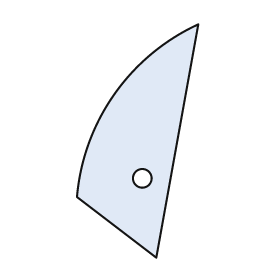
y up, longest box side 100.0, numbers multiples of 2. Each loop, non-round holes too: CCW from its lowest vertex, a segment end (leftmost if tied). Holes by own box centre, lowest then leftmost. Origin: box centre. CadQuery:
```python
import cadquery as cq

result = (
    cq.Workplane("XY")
    .moveTo(8.0, -50.0)
    .lineTo(26.0, 50.0)
    .threePointArc((-10.0, 20.0), (-26.0, -24.0))
    .close()
    .moveTo(2.0, -16.0)
    .circle(4.0)
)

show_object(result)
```